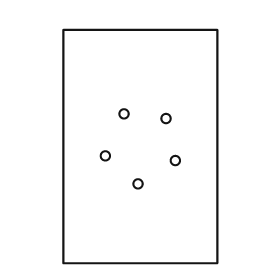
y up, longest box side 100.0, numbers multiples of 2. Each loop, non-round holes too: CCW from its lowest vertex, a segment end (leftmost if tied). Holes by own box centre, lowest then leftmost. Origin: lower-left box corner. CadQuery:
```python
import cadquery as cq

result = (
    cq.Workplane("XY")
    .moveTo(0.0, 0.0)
    .lineTo(66.0, 0.0)
    .lineTo(66.0, 100.0)
    .lineTo(0.0, 100.0)
    .close()
    .moveTo(32.0, 34.0)
    .circle(2.0)
    .moveTo(48.0, 44.0)
    .circle(2.0)
    .moveTo(18.0, 46.0)
    .circle(2.0)
    .moveTo(44.0, 62.0)
    .circle(2.0)
    .moveTo(26.0, 64.0)
    .circle(2.0)
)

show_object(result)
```